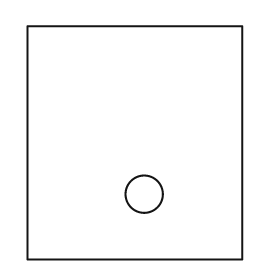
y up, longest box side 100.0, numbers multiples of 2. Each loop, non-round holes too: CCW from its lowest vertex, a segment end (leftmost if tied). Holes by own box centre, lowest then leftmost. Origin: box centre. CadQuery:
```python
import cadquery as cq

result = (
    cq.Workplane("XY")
    .moveTo(-46.0, -50.0)
    .lineTo(46.0, -50.0)
    .lineTo(46.0, 50.0)
    .lineTo(-46.0, 50.0)
    .close()
    .moveTo(4.0, -22.0)
    .circle(8.0)
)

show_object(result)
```